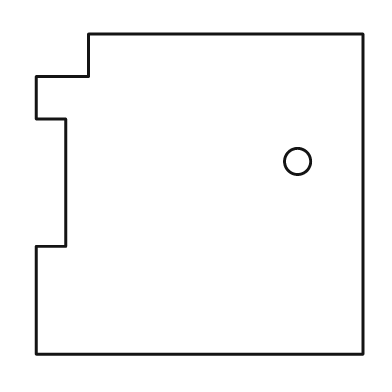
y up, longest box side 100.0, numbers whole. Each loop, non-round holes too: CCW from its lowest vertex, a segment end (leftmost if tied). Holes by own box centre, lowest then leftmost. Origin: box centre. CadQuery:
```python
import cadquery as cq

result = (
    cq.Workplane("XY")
    .moveTo(-50.0, -49.0)
    .lineTo(50.0, -49.0)
    .lineTo(50.0, 49.0)
    .lineTo(-34.0, 49.0)
    .lineTo(-34.0, 36.0)
    .lineTo(-50.0, 36.0)
    .lineTo(-50.0, 23.0)
    .lineTo(-41.0, 23.0)
    .lineTo(-41.0, -16.0)
    .lineTo(-50.0, -16.0)
    .close()
    .moveTo(30.0, 10.0)
    .circle(4.0)
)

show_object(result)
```